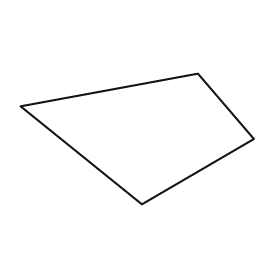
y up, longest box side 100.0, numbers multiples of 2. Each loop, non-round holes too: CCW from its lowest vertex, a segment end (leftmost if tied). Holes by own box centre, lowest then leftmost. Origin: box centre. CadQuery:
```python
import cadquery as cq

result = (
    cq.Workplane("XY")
    .moveTo(2.0, -28.0)
    .lineTo(50.0, 0.0)
    .lineTo(26.0, 28.0)
    .lineTo(-50.0, 14.0)
    .close()
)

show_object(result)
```